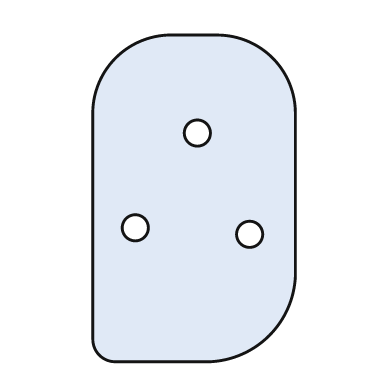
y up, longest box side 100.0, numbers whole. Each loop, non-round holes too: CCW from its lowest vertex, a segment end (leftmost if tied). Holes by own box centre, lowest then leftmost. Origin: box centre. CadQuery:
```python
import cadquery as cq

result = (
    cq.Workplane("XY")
    .moveTo(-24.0, -50.0)
    .lineTo(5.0, -50.0)
    .threePointArc((23.0, -42.0), (31.0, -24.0))
    .lineTo(31.0, 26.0)
    .threePointArc((24.0, 43.0), (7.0, 50.0))
    .lineTo(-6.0, 50.0)
    .threePointArc((-24.0, 43.0), (-31.0, 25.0))
    .lineTo(-31.0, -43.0)
    .threePointArc((-29.0, -48.0), (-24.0, -50.0))
    .close()
    .moveTo(17.0, -11.0)
    .circle(4.0)
    .moveTo(-18.0, -9.0)
    .circle(4.0)
    .moveTo(1.0, 20.0)
    .circle(4.0)
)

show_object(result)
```